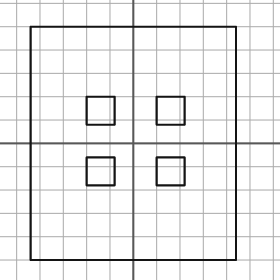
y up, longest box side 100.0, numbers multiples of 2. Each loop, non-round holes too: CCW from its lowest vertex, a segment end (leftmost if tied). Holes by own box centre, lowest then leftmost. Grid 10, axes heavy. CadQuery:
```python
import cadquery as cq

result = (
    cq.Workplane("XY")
    .moveTo(-44.0, -50.0)
    .lineTo(44.0, -50.0)
    .lineTo(44.0, 50.0)
    .lineTo(-44.0, 50.0)
    .close()
    .moveTo(-20.0, -18.0)
    .lineTo(-8.0, -18.0)
    .lineTo(-8.0, -6.0)
    .lineTo(-20.0, -6.0)
    .close()
    .moveTo(10.0, -18.0)
    .lineTo(22.0, -18.0)
    .lineTo(22.0, -6.0)
    .lineTo(10.0, -6.0)
    .close()
    .moveTo(-20.0, 8.0)
    .lineTo(-8.0, 8.0)
    .lineTo(-8.0, 20.0)
    .lineTo(-20.0, 20.0)
    .close()
    .moveTo(10.0, 8.0)
    .lineTo(22.0, 8.0)
    .lineTo(22.0, 20.0)
    .lineTo(10.0, 20.0)
    .close()
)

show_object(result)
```